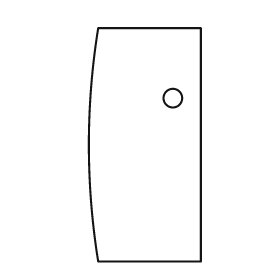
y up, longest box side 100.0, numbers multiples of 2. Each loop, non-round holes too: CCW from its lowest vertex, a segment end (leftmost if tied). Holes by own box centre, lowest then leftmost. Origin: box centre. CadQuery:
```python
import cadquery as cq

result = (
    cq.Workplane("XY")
    .moveTo(-20.0, -50.0)
    .lineTo(24.0, -50.0)
    .lineTo(24.0, 50.0)
    .lineTo(-20.0, 50.0)
    .threePointArc((-24.0, 0.0), (-20.0, -50.0))
    .close()
    .moveTo(12.0, 20.0)
    .circle(4.0)
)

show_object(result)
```